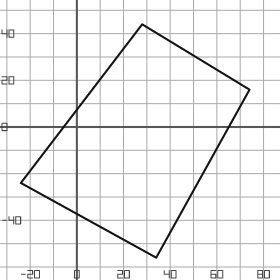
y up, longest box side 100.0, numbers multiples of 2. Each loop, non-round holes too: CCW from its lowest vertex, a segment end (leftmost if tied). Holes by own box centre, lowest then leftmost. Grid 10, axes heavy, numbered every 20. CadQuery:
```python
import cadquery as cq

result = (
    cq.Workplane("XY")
    .moveTo(34.0, -56.0)
    .lineTo(74.0, 16.0)
    .lineTo(28.0, 44.0)
    .lineTo(-24.0, -24.0)
    .close()
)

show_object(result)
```